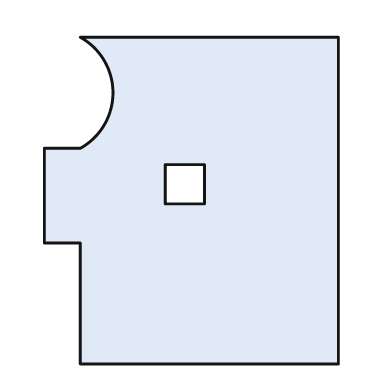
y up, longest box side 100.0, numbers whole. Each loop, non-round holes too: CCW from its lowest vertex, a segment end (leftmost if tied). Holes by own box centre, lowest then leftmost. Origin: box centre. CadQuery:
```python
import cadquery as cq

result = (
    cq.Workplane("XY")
    .moveTo(-34.0, -50.0)
    .lineTo(45.0, -50.0)
    .lineTo(45.0, 50.0)
    .lineTo(-34.0, 50.0)
    .threePointArc((-24.0, 33.0), (-34.0, 16.0))
    .lineTo(-45.0, 16.0)
    .lineTo(-45.0, -13.0)
    .lineTo(-34.0, -13.0)
    .close()
    .moveTo(-8.0, -1.0)
    .lineTo(4.0, -1.0)
    .lineTo(4.0, 11.0)
    .lineTo(-8.0, 11.0)
    .close()
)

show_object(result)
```